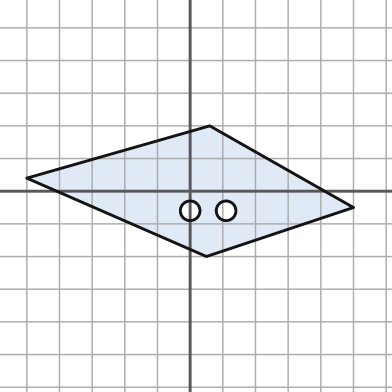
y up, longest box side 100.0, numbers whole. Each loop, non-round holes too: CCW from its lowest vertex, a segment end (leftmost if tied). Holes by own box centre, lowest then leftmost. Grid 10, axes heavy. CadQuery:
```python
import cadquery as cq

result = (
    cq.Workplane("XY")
    .moveTo(5.0, -20.0)
    .lineTo(50.0, -5.0)
    .lineTo(6.0, 20.0)
    .lineTo(-50.0, 4.0)
    .close()
    .moveTo(0.0, -6.0)
    .circle(3.0)
    .moveTo(11.0, -6.0)
    .circle(3.0)
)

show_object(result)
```